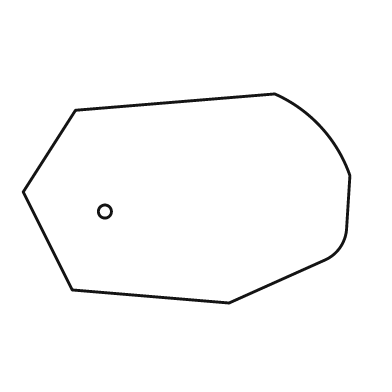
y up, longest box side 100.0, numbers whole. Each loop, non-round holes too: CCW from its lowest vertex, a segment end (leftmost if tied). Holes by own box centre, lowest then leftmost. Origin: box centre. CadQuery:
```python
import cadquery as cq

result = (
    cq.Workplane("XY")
    .moveTo(13.0, -32.0)
    .lineTo(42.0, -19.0)
    .threePointArc((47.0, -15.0), (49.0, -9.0))
    .lineTo(50.0, 7.0)
    .threePointArc((41.0, 22.0), (27.0, 32.0))
    .lineTo(-34.0, 27.0)
    .lineTo(-50.0, 2.0)
    .lineTo(-35.0, -28.0)
    .close()
    .moveTo(-25.0, -4.0)
    .circle(2.0)
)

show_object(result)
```